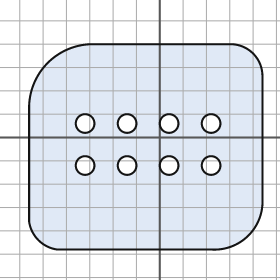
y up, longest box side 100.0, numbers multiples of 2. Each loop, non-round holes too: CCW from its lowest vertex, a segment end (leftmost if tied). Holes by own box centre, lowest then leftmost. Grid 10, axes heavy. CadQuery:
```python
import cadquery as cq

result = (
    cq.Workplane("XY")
    .moveTo(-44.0, -48.0)
    .lineTo(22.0, -48.0)
    .threePointArc((38.0, -42.0), (44.0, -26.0))
    .lineTo(44.0, 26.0)
    .threePointArc((40.0, 36.0), (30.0, 40.0))
    .lineTo(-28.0, 40.0)
    .threePointArc((-48.0, 32.0), (-56.0, 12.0))
    .lineTo(-56.0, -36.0)
    .threePointArc((-52.0, -44.0), (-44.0, -48.0))
    .close()
    .moveTo(-32.0, -12.0)
    .circle(4.0)
    .moveTo(-14.0, -12.0)
    .circle(4.0)
    .moveTo(4.0, -12.0)
    .circle(4.0)
    .moveTo(22.0, -12.0)
    .circle(4.0)
    .moveTo(-32.0, 6.0)
    .circle(4.0)
    .moveTo(-14.0, 6.0)
    .circle(4.0)
    .moveTo(4.0, 6.0)
    .circle(4.0)
    .moveTo(22.0, 6.0)
    .circle(4.0)
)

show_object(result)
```